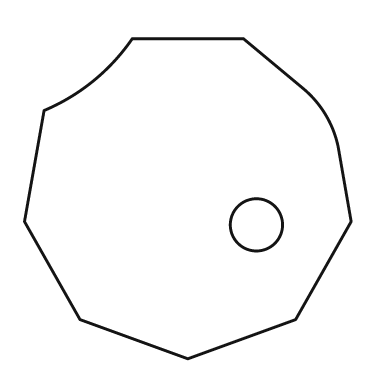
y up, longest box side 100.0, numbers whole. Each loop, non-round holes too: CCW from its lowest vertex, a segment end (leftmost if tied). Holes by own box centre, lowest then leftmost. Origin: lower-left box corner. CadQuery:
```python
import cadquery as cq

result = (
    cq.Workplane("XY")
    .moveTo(50.0, 0.0)
    .lineTo(83.0, 12.0)
    .lineTo(100.0, 42.0)
    .lineTo(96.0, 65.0)
    .threePointArc((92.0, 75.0), (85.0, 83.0))
    .lineTo(67.0, 98.0)
    .lineTo(33.0, 98.0)
    .threePointArc((21.0, 85.0), (6.0, 76.0))
    .lineTo(0.0, 42.0)
    .lineTo(17.0, 12.0)
    .close()
    .moveTo(71.0, 41.0)
    .circle(8.0)
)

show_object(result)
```